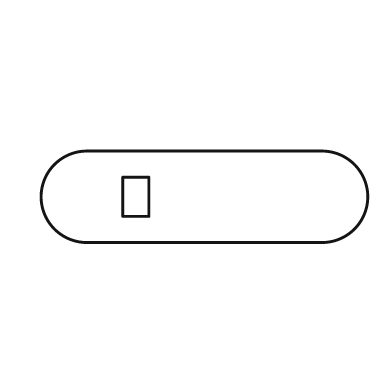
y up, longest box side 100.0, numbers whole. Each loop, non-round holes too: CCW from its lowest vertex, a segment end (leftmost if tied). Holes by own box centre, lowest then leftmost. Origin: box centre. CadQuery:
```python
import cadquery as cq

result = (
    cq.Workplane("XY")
    .moveTo(-36.0, -14.0)
    .lineTo(36.0, -14.0)
    .threePointArc((50.0, 0.0), (36.0, 14.0))
    .lineTo(-36.0, 14.0)
    .threePointArc((-50.0, 0.0), (-36.0, -14.0))
    .close()
    .moveTo(-25.0, -6.0)
    .lineTo(-17.0, -6.0)
    .lineTo(-17.0, 6.0)
    .lineTo(-25.0, 6.0)
    .close()
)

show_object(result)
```